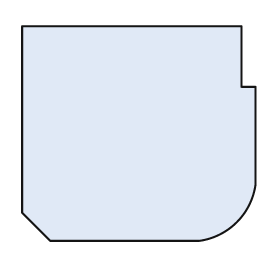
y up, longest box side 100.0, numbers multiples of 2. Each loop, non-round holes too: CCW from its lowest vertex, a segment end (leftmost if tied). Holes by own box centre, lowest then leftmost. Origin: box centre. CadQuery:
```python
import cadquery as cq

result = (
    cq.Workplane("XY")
    .moveTo(-38.0, -46.0)
    .lineTo(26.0, -46.0)
    .threePointArc((42.0, -38.0), (50.0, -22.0))
    .lineTo(50.0, 20.0)
    .lineTo(44.0, 20.0)
    .lineTo(44.0, 46.0)
    .lineTo(-50.0, 46.0)
    .lineTo(-50.0, -34.0)
    .close()
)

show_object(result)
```